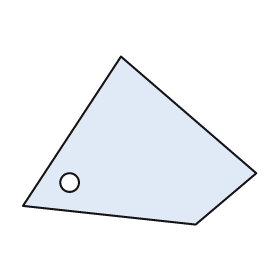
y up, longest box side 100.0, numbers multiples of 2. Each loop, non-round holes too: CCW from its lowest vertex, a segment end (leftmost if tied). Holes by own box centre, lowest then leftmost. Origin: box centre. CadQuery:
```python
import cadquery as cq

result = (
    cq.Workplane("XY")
    .moveTo(24.0, -36.0)
    .lineTo(50.0, -14.0)
    .lineTo(-8.0, 36.0)
    .lineTo(-50.0, -28.0)
    .close()
    .moveTo(-30.0, -18.0)
    .circle(4.0)
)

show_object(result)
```